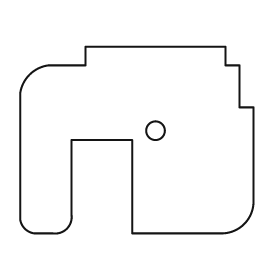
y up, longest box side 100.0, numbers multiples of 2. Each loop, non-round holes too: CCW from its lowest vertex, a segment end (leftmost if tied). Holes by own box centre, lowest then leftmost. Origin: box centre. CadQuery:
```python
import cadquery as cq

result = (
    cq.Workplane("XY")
    .moveTo(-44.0, -40.0)
    .lineTo(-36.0, -40.0)
    .threePointArc((-30.0, -38.0), (-28.0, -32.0))
    .lineTo(-28.0, 0.0)
    .lineTo(-2.0, 0.0)
    .lineTo(-2.0, -40.0)
    .lineTo(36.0, -40.0)
    .threePointArc((46.0, -36.0), (50.0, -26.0))
    .lineTo(50.0, 14.0)
    .lineTo(44.0, 14.0)
    .lineTo(44.0, 32.0)
    .lineTo(38.0, 32.0)
    .lineTo(38.0, 40.0)
    .lineTo(-22.0, 40.0)
    .lineTo(-22.0, 32.0)
    .lineTo(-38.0, 32.0)
    .threePointArc((-46.0, 28.0), (-50.0, 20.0))
    .lineTo(-50.0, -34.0)
    .threePointArc((-48.0, -38.0), (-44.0, -40.0))
    .close()
    .moveTo(8.0, 4.0)
    .circle(4.0)
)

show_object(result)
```